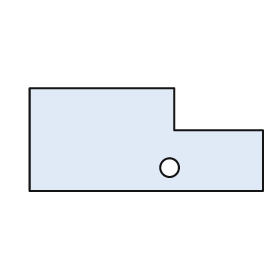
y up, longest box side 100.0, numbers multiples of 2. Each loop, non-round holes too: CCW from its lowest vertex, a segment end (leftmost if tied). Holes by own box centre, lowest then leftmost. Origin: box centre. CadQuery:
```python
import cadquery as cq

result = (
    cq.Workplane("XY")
    .moveTo(-50.0, -22.0)
    .lineTo(50.0, -22.0)
    .lineTo(50.0, 4.0)
    .lineTo(12.0, 4.0)
    .lineTo(12.0, 22.0)
    .lineTo(-50.0, 22.0)
    .close()
    .moveTo(10.0, -12.0)
    .circle(4.0)
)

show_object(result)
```